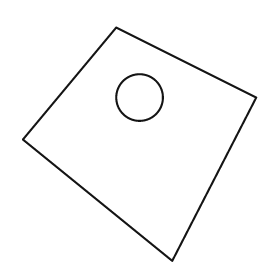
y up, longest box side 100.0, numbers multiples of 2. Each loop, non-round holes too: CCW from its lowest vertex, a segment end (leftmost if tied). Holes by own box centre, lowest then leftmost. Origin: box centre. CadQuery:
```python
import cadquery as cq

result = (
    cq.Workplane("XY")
    .moveTo(14.0, -50.0)
    .lineTo(50.0, 20.0)
    .lineTo(-10.0, 50.0)
    .lineTo(-50.0, 2.0)
    .close()
    .moveTo(0.0, 20.0)
    .circle(10.0)
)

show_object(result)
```